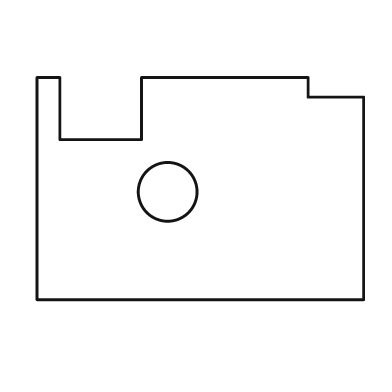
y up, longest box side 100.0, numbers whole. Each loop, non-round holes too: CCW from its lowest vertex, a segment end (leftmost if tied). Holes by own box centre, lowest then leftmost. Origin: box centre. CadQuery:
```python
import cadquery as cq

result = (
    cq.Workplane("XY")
    .moveTo(-50.0, -34.0)
    .lineTo(50.0, -34.0)
    .lineTo(50.0, 28.0)
    .lineTo(33.0, 28.0)
    .lineTo(33.0, 34.0)
    .lineTo(-18.0, 34.0)
    .lineTo(-18.0, 15.0)
    .lineTo(-43.0, 15.0)
    .lineTo(-43.0, 34.0)
    .lineTo(-50.0, 34.0)
    .close()
    .moveTo(-10.0, -1.0)
    .circle(9.0)
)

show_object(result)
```